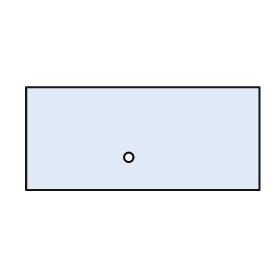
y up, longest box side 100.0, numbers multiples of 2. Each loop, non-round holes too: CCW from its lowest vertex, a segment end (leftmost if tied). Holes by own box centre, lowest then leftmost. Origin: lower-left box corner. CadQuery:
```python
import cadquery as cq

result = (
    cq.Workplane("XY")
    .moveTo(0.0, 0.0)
    .lineTo(100.0, 0.0)
    .lineTo(100.0, 44.0)
    .lineTo(0.0, 44.0)
    .close()
    .moveTo(44.0, 14.0)
    .circle(2.0)
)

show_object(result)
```